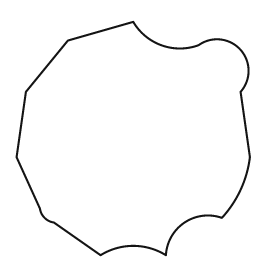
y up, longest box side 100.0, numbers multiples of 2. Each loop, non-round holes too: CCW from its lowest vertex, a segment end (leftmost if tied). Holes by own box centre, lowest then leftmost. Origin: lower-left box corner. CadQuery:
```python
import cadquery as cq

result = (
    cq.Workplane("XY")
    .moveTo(36.0, 0.0)
    .threePointArc((50.0, 4.0), (64.0, 0.0))
    .threePointArc((72.0, 14.0), (88.0, 16.0))
    .threePointArc((96.0, 28.0), (100.0, 42.0))
    .lineTo(96.0, 70.0)
    .threePointArc((96.0, 88.0), (78.0, 90.0))
    .threePointArc((62.0, 90.0), (50.0, 100.0))
    .lineTo(22.0, 92.0)
    .lineTo(4.0, 70.0)
    .lineTo(0.0, 42.0)
    .lineTo(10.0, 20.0)
    .threePointArc((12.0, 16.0), (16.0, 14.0))
    .close()
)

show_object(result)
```